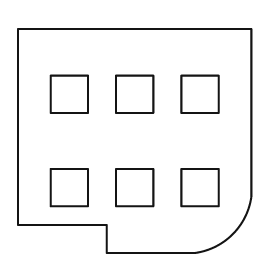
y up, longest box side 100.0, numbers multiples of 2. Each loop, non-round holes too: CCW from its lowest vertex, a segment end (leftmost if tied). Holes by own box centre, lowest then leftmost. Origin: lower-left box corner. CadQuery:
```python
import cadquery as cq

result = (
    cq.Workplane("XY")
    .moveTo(38.0, 0.0)
    .lineTo(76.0, 0.0)
    .threePointArc((92.0, 8.0), (100.0, 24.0))
    .lineTo(100.0, 96.0)
    .lineTo(0.0, 96.0)
    .lineTo(0.0, 12.0)
    .lineTo(38.0, 12.0)
    .close()
    .moveTo(14.0, 20.0)
    .lineTo(30.0, 20.0)
    .lineTo(30.0, 36.0)
    .lineTo(14.0, 36.0)
    .close()
    .moveTo(42.0, 20.0)
    .lineTo(58.0, 20.0)
    .lineTo(58.0, 36.0)
    .lineTo(42.0, 36.0)
    .close()
    .moveTo(70.0, 20.0)
    .lineTo(86.0, 20.0)
    .lineTo(86.0, 36.0)
    .lineTo(70.0, 36.0)
    .close()
    .moveTo(14.0, 60.0)
    .lineTo(30.0, 60.0)
    .lineTo(30.0, 76.0)
    .lineTo(14.0, 76.0)
    .close()
    .moveTo(42.0, 60.0)
    .lineTo(58.0, 60.0)
    .lineTo(58.0, 76.0)
    .lineTo(42.0, 76.0)
    .close()
    .moveTo(70.0, 60.0)
    .lineTo(86.0, 60.0)
    .lineTo(86.0, 76.0)
    .lineTo(70.0, 76.0)
    .close()
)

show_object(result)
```